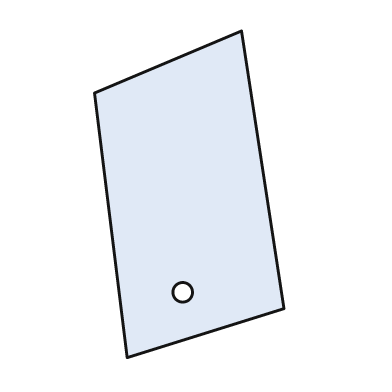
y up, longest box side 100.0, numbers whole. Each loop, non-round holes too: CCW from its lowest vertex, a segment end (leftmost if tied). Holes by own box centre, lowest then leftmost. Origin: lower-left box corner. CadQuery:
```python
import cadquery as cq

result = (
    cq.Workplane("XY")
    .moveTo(10.0, 0.0)
    .lineTo(58.0, 15.0)
    .lineTo(45.0, 100.0)
    .lineTo(0.0, 81.0)
    .close()
    .moveTo(27.0, 20.0)
    .circle(3.0)
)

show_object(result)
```